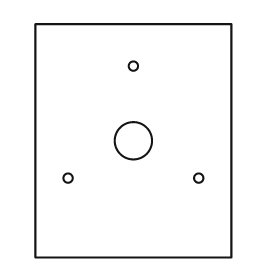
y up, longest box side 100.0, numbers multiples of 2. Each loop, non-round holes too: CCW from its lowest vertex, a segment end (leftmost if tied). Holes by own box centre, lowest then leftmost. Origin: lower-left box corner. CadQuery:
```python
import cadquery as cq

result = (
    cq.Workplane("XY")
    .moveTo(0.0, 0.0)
    .lineTo(84.0, 0.0)
    .lineTo(84.0, 100.0)
    .lineTo(0.0, 100.0)
    .close()
    .moveTo(14.0, 34.0)
    .circle(2.0)
    .moveTo(70.0, 34.0)
    .circle(2.0)
    .moveTo(42.0, 50.0)
    .circle(8.0)
    .moveTo(42.0, 82.0)
    .circle(2.0)
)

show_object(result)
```